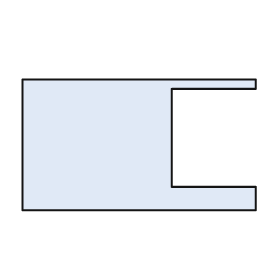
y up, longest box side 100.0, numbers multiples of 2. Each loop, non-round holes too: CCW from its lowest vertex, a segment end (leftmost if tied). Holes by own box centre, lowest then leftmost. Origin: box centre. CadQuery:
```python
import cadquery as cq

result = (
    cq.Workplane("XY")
    .moveTo(-50.0, -28.0)
    .lineTo(50.0, -28.0)
    .lineTo(50.0, -18.0)
    .lineTo(14.0, -18.0)
    .lineTo(14.0, 24.0)
    .lineTo(50.0, 24.0)
    .lineTo(50.0, 28.0)
    .lineTo(-50.0, 28.0)
    .close()
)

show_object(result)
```